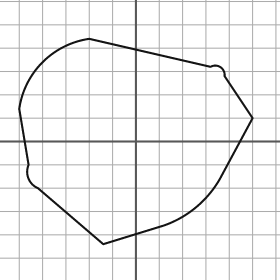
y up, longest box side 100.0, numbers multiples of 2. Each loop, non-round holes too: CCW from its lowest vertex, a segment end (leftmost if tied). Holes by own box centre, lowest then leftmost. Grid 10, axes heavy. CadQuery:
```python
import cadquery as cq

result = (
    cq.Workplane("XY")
    .moveTo(-14.0, -44.0)
    .lineTo(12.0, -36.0)
    .threePointArc((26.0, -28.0), (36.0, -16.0))
    .lineTo(50.0, 10.0)
    .lineTo(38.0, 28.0)
    .threePointArc((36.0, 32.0), (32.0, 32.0))
    .lineTo(-20.0, 44.0)
    .threePointArc((-40.0, 34.0), (-50.0, 14.0))
    .lineTo(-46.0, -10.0)
    .threePointArc((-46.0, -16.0), (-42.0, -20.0))
    .close()
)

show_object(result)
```